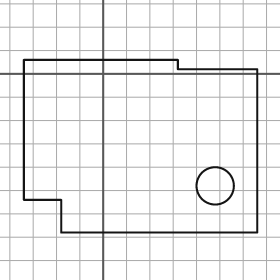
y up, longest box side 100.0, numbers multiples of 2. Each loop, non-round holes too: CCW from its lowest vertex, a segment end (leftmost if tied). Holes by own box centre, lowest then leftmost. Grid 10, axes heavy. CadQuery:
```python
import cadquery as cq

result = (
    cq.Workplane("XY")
    .moveTo(-18.0, -68.0)
    .lineTo(66.0, -68.0)
    .lineTo(66.0, 2.0)
    .lineTo(32.0, 2.0)
    .lineTo(32.0, 6.0)
    .lineTo(-34.0, 6.0)
    .lineTo(-34.0, -54.0)
    .lineTo(-18.0, -54.0)
    .close()
    .moveTo(48.0, -48.0)
    .circle(8.0)
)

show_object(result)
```